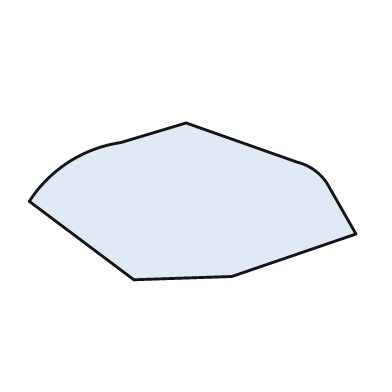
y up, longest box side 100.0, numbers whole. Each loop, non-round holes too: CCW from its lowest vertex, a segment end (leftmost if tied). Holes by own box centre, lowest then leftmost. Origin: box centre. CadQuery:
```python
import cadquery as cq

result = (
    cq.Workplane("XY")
    .moveTo(-18.0, -24.0)
    .lineTo(12.0, -23.0)
    .lineTo(50.0, -10.0)
    .lineTo(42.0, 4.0)
    .threePointArc((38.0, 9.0), (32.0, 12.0))
    .lineTo(-2.0, 24.0)
    .lineTo(-22.0, 18.0)
    .threePointArc((-38.0, 12.0), (-50.0, 0.0))
    .close()
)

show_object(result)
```